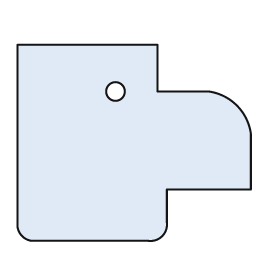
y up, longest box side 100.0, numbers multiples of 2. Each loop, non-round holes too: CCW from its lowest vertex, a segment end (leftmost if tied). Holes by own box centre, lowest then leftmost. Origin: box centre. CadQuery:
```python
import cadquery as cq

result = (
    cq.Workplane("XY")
    .moveTo(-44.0, -42.0)
    .lineTo(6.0, -42.0)
    .threePointArc((12.0, -40.0), (14.0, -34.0))
    .lineTo(14.0, -20.0)
    .lineTo(50.0, -20.0)
    .lineTo(50.0, 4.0)
    .threePointArc((44.0, 16.0), (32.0, 22.0))
    .lineTo(10.0, 22.0)
    .lineTo(10.0, 42.0)
    .lineTo(-50.0, 42.0)
    .lineTo(-50.0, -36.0)
    .threePointArc((-48.0, -40.0), (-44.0, -42.0))
    .close()
    .moveTo(-8.0, 22.0)
    .circle(4.0)
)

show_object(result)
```